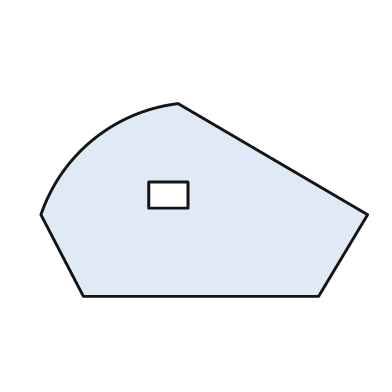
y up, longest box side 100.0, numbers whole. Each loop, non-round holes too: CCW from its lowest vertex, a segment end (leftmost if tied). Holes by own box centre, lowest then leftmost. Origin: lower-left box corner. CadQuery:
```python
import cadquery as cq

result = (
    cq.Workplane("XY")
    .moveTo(13.0, 0.0)
    .lineTo(85.0, 0.0)
    .lineTo(100.0, 25.0)
    .lineTo(42.0, 59.0)
    .threePointArc((16.0, 48.0), (0.0, 25.0))
    .close()
    .moveTo(33.0, 27.0)
    .lineTo(45.0, 27.0)
    .lineTo(45.0, 35.0)
    .lineTo(33.0, 35.0)
    .close()
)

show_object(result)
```